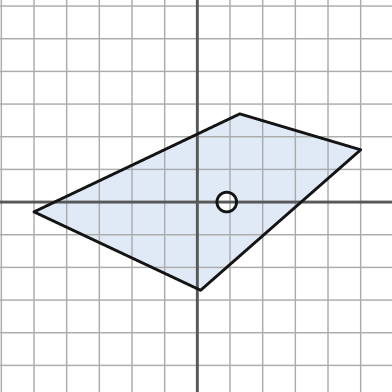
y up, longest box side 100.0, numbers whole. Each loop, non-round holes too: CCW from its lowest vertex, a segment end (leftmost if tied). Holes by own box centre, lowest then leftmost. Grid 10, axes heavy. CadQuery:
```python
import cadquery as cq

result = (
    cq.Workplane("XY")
    .moveTo(1.0, -27.0)
    .lineTo(50.0, 16.0)
    .lineTo(13.0, 27.0)
    .lineTo(-50.0, -3.0)
    .close()
    .moveTo(9.0, 0.0)
    .circle(3.0)
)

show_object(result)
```